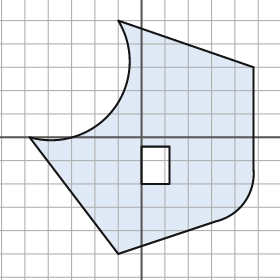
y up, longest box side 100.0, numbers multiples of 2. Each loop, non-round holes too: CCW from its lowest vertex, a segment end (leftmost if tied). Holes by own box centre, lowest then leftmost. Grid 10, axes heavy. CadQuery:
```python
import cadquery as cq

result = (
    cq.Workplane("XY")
    .moveTo(-10.0, -50.0)
    .lineTo(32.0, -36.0)
    .threePointArc((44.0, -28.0), (48.0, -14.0))
    .lineTo(48.0, 30.0)
    .lineTo(-10.0, 50.0)
    .threePointArc((-12.0, 12.0), (-48.0, 0.0))
    .close()
    .moveTo(0.0, -20.0)
    .lineTo(12.0, -20.0)
    .lineTo(12.0, -4.0)
    .lineTo(0.0, -4.0)
    .close()
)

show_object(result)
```